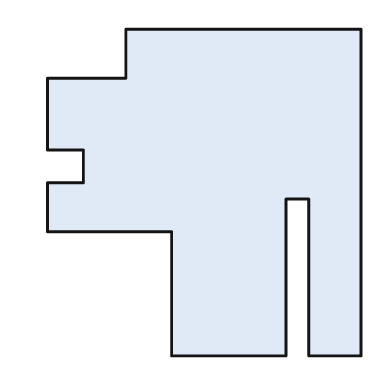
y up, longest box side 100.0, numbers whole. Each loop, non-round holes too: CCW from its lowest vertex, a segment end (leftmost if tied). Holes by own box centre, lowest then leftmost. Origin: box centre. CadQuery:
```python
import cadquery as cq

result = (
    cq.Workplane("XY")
    .moveTo(-10.0, -50.0)
    .lineTo(25.0, -50.0)
    .lineTo(25.0, -2.0)
    .lineTo(32.0, -2.0)
    .lineTo(32.0, -50.0)
    .lineTo(48.0, -50.0)
    .lineTo(48.0, 50.0)
    .lineTo(-24.0, 50.0)
    .lineTo(-24.0, 35.0)
    .lineTo(-48.0, 35.0)
    .lineTo(-48.0, 13.0)
    .lineTo(-37.0, 13.0)
    .lineTo(-37.0, 3.0)
    .lineTo(-48.0, 3.0)
    .lineTo(-48.0, -12.0)
    .lineTo(-10.0, -12.0)
    .close()
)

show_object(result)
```